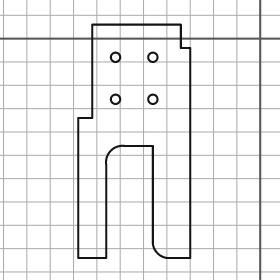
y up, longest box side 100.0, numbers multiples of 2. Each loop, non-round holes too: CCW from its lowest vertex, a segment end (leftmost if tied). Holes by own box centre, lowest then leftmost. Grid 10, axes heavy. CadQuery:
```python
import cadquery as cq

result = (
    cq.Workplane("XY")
    .moveTo(-78.0, -94.0)
    .lineTo(-66.0, -94.0)
    .lineTo(-66.0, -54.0)
    .threePointArc((-64.0, -48.0), (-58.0, -46.0))
    .lineTo(-46.0, -46.0)
    .lineTo(-46.0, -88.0)
    .threePointArc((-44.0, -92.0), (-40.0, -94.0))
    .lineTo(-30.0, -94.0)
    .lineTo(-30.0, -4.0)
    .lineTo(-34.0, -4.0)
    .lineTo(-34.0, 6.0)
    .lineTo(-72.0, 6.0)
    .lineTo(-72.0, -34.0)
    .lineTo(-78.0, -34.0)
    .close()
    .moveTo(-62.0, -26.0)
    .circle(2.0)
    .moveTo(-46.0, -26.0)
    .circle(2.0)
    .moveTo(-62.0, -8.0)
    .circle(2.0)
    .moveTo(-46.0, -8.0)
    .circle(2.0)
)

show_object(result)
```